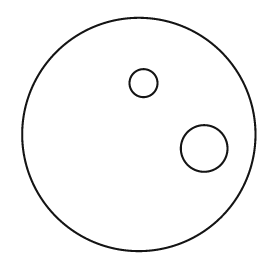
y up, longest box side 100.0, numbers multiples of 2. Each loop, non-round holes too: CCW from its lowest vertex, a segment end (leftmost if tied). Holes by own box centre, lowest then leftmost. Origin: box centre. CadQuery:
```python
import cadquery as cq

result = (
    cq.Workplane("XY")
    .moveTo(0.0, 0.0)
    .circle(50.0)
    .moveTo(28.0, -6.0)
    .circle(10.0)
    .moveTo(2.0, 22.0)
    .circle(6.0)
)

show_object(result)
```